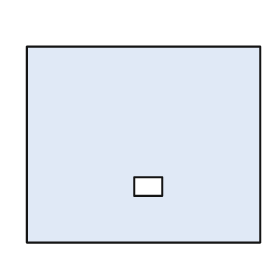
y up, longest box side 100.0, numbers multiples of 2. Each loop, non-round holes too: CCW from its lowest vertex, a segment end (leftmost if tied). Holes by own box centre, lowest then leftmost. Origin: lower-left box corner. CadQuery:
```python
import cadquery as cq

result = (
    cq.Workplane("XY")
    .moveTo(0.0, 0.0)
    .lineTo(100.0, 0.0)
    .lineTo(100.0, 84.0)
    .lineTo(0.0, 84.0)
    .close()
    .moveTo(46.0, 20.0)
    .lineTo(58.0, 20.0)
    .lineTo(58.0, 28.0)
    .lineTo(46.0, 28.0)
    .close()
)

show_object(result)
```